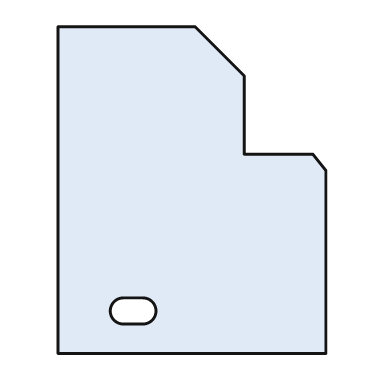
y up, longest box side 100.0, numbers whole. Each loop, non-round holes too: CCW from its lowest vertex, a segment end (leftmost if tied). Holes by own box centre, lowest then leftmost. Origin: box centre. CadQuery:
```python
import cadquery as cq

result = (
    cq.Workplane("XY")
    .moveTo(-41.0, -50.0)
    .lineTo(41.0, -50.0)
    .lineTo(41.0, 6.0)
    .lineTo(37.0, 11.0)
    .lineTo(16.0, 11.0)
    .lineTo(16.0, 35.0)
    .lineTo(1.0, 50.0)
    .lineTo(-41.0, 50.0)
    .close()
    .moveTo(-21.0, -41.0)
    .lineTo(-15.0, -41.0)
    .threePointArc((-11.0, -37.0), (-15.0, -33.0))
    .lineTo(-21.0, -33.0)
    .threePointArc((-25.0, -37.0), (-21.0, -41.0))
    .close()
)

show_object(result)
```